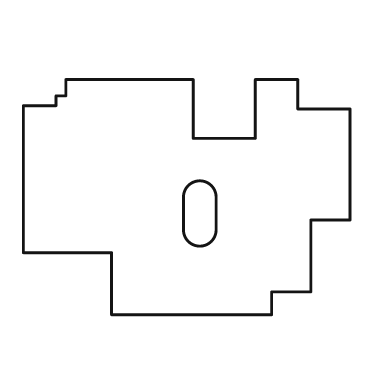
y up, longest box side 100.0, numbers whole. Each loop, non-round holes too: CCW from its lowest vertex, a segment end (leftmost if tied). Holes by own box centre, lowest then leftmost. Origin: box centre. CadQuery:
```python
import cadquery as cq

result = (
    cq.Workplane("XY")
    .moveTo(-23.0, -36.0)
    .lineTo(26.0, -36.0)
    .lineTo(26.0, -29.0)
    .lineTo(38.0, -29.0)
    .lineTo(38.0, -7.0)
    .lineTo(50.0, -7.0)
    .lineTo(50.0, 27.0)
    .lineTo(34.0, 27.0)
    .lineTo(34.0, 36.0)
    .lineTo(21.0, 36.0)
    .lineTo(21.0, 18.0)
    .lineTo(2.0, 18.0)
    .lineTo(2.0, 36.0)
    .lineTo(-37.0, 36.0)
    .lineTo(-37.0, 31.0)
    .lineTo(-40.0, 31.0)
    .lineTo(-40.0, 28.0)
    .lineTo(-50.0, 28.0)
    .lineTo(-50.0, -17.0)
    .lineTo(-23.0, -17.0)
    .close()
    .moveTo(-1.0, -10.0)
    .threePointArc((4.0, -15.0), (9.0, -10.0))
    .lineTo(9.0, 0.0)
    .threePointArc((4.0, 5.0), (-1.0, 0.0))
    .close()
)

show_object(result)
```